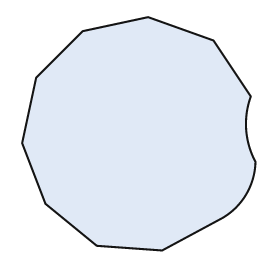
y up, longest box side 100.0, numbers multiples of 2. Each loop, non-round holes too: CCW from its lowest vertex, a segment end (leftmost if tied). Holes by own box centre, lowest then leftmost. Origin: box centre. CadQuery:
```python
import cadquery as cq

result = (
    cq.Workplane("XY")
    .moveTo(10.0, -50.0)
    .lineTo(36.0, -36.0)
    .threePointArc((46.0, -26.0), (50.0, -12.0))
    .threePointArc((46.0, 2.0), (48.0, 16.0))
    .lineTo(32.0, 40.0)
    .lineTo(4.0, 50.0)
    .lineTo(-24.0, 44.0)
    .lineTo(-44.0, 24.0)
    .lineTo(-50.0, -4.0)
    .lineTo(-40.0, -30.0)
    .lineTo(-18.0, -48.0)
    .close()
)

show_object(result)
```